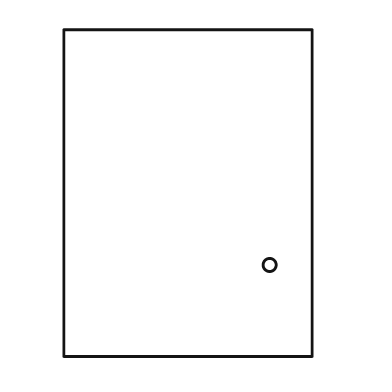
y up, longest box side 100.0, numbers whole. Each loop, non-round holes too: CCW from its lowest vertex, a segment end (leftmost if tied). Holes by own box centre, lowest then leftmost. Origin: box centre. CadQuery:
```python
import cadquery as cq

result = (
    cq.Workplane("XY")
    .moveTo(-38.0, -50.0)
    .lineTo(38.0, -50.0)
    .lineTo(38.0, 50.0)
    .lineTo(-38.0, 50.0)
    .close()
    .moveTo(25.0, -22.0)
    .circle(2.0)
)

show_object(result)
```